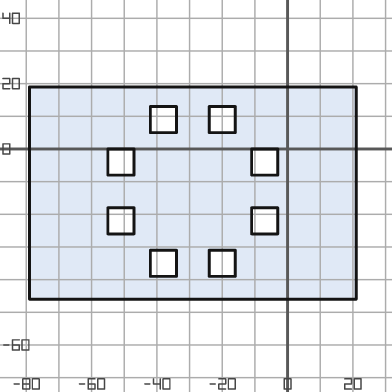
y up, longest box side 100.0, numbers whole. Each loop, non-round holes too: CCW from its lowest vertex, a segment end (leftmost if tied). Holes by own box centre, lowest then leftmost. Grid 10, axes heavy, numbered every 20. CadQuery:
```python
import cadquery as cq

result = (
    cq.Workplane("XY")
    .moveTo(-79.0, -46.0)
    .lineTo(21.0, -46.0)
    .lineTo(21.0, 19.0)
    .lineTo(-79.0, 19.0)
    .close()
    .moveTo(-42.0, -39.0)
    .lineTo(-34.0, -39.0)
    .lineTo(-34.0, -31.0)
    .lineTo(-42.0, -31.0)
    .close()
    .moveTo(-24.0, -39.0)
    .lineTo(-16.0, -39.0)
    .lineTo(-16.0, -31.0)
    .lineTo(-24.0, -31.0)
    .close()
    .moveTo(-55.0, -26.0)
    .lineTo(-47.0, -26.0)
    .lineTo(-47.0, -18.0)
    .lineTo(-55.0, -18.0)
    .close()
    .moveTo(-11.0, -26.0)
    .lineTo(-3.0, -26.0)
    .lineTo(-3.0, -18.0)
    .lineTo(-11.0, -18.0)
    .close()
    .moveTo(-55.0, -8.0)
    .lineTo(-47.0, -8.0)
    .lineTo(-47.0, 0.0)
    .lineTo(-55.0, 0.0)
    .close()
    .moveTo(-11.0, -8.0)
    .lineTo(-3.0, -8.0)
    .lineTo(-3.0, 0.0)
    .lineTo(-11.0, 0.0)
    .close()
    .moveTo(-42.0, 5.0)
    .lineTo(-34.0, 5.0)
    .lineTo(-34.0, 13.0)
    .lineTo(-42.0, 13.0)
    .close()
    .moveTo(-24.0, 5.0)
    .lineTo(-16.0, 5.0)
    .lineTo(-16.0, 13.0)
    .lineTo(-24.0, 13.0)
    .close()
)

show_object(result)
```